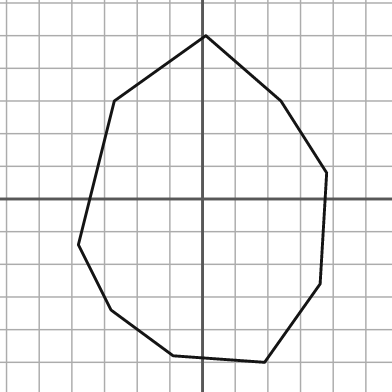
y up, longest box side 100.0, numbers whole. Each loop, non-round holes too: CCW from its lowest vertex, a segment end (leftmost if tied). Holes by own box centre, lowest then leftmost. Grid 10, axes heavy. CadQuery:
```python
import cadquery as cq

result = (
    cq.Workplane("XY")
    .moveTo(19.0, -50.0)
    .lineTo(36.0, -26.0)
    .lineTo(38.0, 8.0)
    .lineTo(24.0, 30.0)
    .lineTo(1.0, 50.0)
    .lineTo(-27.0, 30.0)
    .lineTo(-38.0, -14.0)
    .lineTo(-28.0, -34.0)
    .lineTo(-9.0, -48.0)
    .close()
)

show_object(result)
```